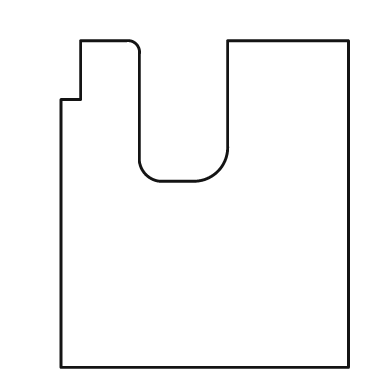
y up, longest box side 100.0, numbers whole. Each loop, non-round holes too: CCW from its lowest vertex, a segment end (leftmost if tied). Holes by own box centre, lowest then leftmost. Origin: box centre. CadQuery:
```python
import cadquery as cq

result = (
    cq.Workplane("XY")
    .moveTo(-44.0, -50.0)
    .lineTo(44.0, -50.0)
    .lineTo(44.0, 50.0)
    .lineTo(7.0, 50.0)
    .lineTo(7.0, 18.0)
    .threePointArc((4.0, 10.0), (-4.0, 7.0))
    .lineTo(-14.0, 7.0)
    .threePointArc((-18.0, 9.0), (-20.0, 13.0))
    .lineTo(-20.0, 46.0)
    .threePointArc((-21.0, 49.0), (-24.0, 50.0))
    .lineTo(-38.0, 50.0)
    .lineTo(-38.0, 32.0)
    .lineTo(-44.0, 32.0)
    .close()
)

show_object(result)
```